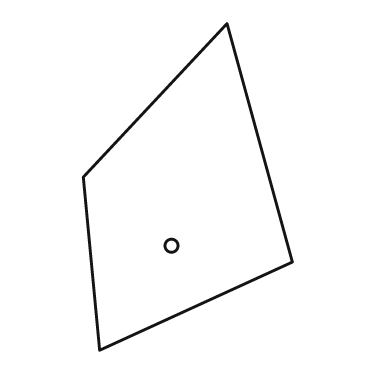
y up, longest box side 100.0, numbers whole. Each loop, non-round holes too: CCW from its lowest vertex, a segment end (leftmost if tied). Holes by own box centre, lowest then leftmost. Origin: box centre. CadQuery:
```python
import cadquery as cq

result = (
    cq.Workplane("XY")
    .moveTo(-27.0, -50.0)
    .lineTo(32.0, -23.0)
    .lineTo(12.0, 50.0)
    .lineTo(-32.0, 3.0)
    .close()
    .moveTo(-5.0, -18.0)
    .circle(2.0)
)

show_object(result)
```